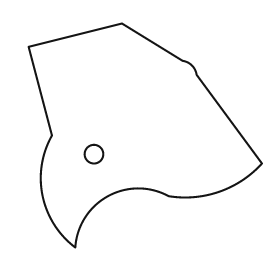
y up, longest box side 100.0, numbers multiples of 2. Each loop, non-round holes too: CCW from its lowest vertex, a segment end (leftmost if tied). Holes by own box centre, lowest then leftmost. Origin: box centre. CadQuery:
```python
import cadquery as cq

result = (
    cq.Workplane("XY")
    .moveTo(-30.0, -48.0)
    .threePointArc((-16.0, -26.0), (10.0, -26.0))
    .threePointArc((32.0, -24.0), (50.0, -12.0))
    .lineTo(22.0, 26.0)
    .threePointArc((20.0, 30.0), (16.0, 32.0))
    .lineTo(-10.0, 48.0)
    .lineTo(-50.0, 38.0)
    .lineTo(-40.0, 0.0)
    .threePointArc((-44.0, -26.0), (-30.0, -48.0))
    .close()
    .moveTo(-22.0, -8.0)
    .circle(4.0)
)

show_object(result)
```